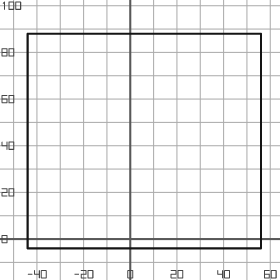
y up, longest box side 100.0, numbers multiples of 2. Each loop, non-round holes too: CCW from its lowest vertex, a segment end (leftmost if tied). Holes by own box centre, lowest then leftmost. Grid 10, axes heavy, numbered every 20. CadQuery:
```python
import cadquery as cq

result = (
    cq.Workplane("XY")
    .moveTo(-44.0, -4.0)
    .lineTo(56.0, -4.0)
    .lineTo(56.0, 88.0)
    .lineTo(-44.0, 88.0)
    .close()
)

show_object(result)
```